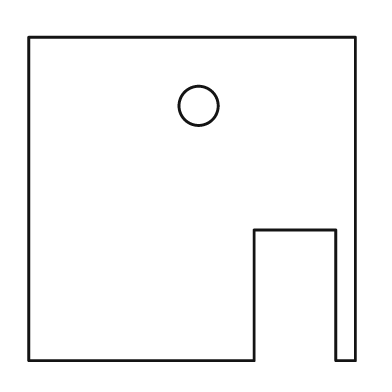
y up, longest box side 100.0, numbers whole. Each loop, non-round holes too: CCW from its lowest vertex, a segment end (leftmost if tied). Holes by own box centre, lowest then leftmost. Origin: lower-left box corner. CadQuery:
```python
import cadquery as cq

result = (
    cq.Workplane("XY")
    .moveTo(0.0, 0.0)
    .lineTo(69.0, 0.0)
    .lineTo(69.0, 40.0)
    .lineTo(94.0, 40.0)
    .lineTo(94.0, 0.0)
    .lineTo(100.0, 0.0)
    .lineTo(100.0, 99.0)
    .lineTo(0.0, 99.0)
    .close()
    .moveTo(52.0, 78.0)
    .circle(6.0)
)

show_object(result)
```